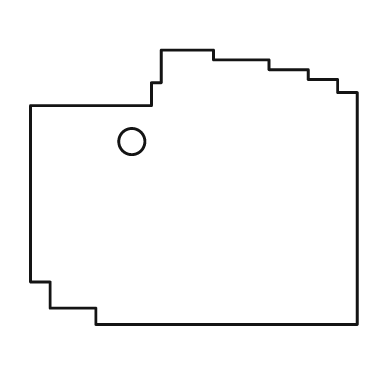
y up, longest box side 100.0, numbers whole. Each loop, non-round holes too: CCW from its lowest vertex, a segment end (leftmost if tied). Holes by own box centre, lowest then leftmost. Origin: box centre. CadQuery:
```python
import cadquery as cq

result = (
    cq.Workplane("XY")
    .moveTo(-30.0, -42.0)
    .lineTo(50.0, -42.0)
    .lineTo(50.0, 29.0)
    .lineTo(44.0, 29.0)
    .lineTo(44.0, 33.0)
    .lineTo(35.0, 33.0)
    .lineTo(35.0, 36.0)
    .lineTo(23.0, 36.0)
    .lineTo(23.0, 39.0)
    .lineTo(6.0, 39.0)
    .lineTo(6.0, 42.0)
    .lineTo(-10.0, 42.0)
    .lineTo(-10.0, 32.0)
    .lineTo(-13.0, 32.0)
    .lineTo(-13.0, 25.0)
    .lineTo(-50.0, 25.0)
    .lineTo(-50.0, -29.0)
    .lineTo(-44.0, -29.0)
    .lineTo(-44.0, -37.0)
    .lineTo(-30.0, -37.0)
    .close()
    .moveTo(-19.0, 14.0)
    .circle(4.0)
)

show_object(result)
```